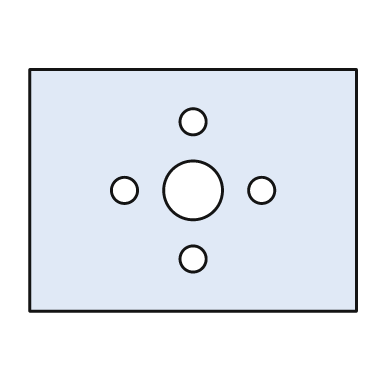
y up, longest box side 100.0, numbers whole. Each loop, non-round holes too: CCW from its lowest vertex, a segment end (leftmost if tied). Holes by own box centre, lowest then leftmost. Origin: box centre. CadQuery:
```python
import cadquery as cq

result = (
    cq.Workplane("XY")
    .moveTo(-50.0, -37.0)
    .lineTo(50.0, -37.0)
    .lineTo(50.0, 37.0)
    .lineTo(-50.0, 37.0)
    .close()
    .moveTo(0.0, -21.0)
    .circle(4.0)
    .moveTo(-21.0, 0.0)
    .circle(4.0)
    .moveTo(0.0, 0.0)
    .circle(9.0)
    .moveTo(21.0, 0.0)
    .circle(4.0)
    .moveTo(0.0, 21.0)
    .circle(4.0)
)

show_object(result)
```